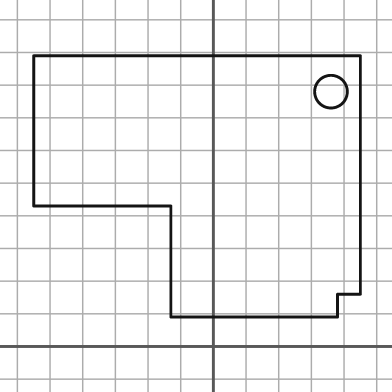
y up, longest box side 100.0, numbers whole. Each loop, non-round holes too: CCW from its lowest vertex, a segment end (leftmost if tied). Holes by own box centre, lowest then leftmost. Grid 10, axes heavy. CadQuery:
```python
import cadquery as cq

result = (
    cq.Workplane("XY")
    .moveTo(-13.0, 9.0)
    .lineTo(38.0, 9.0)
    .lineTo(38.0, 16.0)
    .lineTo(45.0, 16.0)
    .lineTo(45.0, 89.0)
    .lineTo(-55.0, 89.0)
    .lineTo(-55.0, 43.0)
    .lineTo(-13.0, 43.0)
    .close()
    .moveTo(36.0, 78.0)
    .circle(5.0)
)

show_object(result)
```